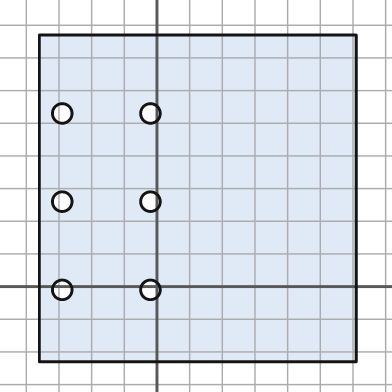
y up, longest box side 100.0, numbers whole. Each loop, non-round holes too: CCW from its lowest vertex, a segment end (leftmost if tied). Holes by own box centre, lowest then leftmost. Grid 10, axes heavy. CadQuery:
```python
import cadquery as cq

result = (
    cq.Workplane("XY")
    .moveTo(-36.0, -23.0)
    .lineTo(61.0, -23.0)
    .lineTo(61.0, 77.0)
    .lineTo(-36.0, 77.0)
    .close()
    .moveTo(-29.0, -1.0)
    .circle(3.0)
    .moveTo(-2.0, -1.0)
    .circle(3.0)
    .moveTo(-29.0, 26.0)
    .circle(3.0)
    .moveTo(-2.0, 26.0)
    .circle(3.0)
    .moveTo(-29.0, 53.0)
    .circle(3.0)
    .moveTo(-2.0, 53.0)
    .circle(3.0)
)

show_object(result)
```